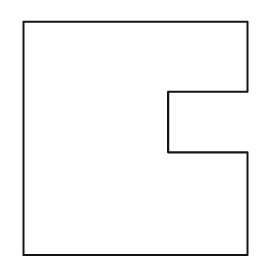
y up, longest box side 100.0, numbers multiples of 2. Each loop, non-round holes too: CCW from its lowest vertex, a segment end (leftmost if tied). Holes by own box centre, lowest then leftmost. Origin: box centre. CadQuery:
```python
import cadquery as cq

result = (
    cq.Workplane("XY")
    .moveTo(-48.0, -50.0)
    .lineTo(48.0, -50.0)
    .lineTo(48.0, -6.0)
    .lineTo(14.0, -6.0)
    .lineTo(14.0, 20.0)
    .lineTo(48.0, 20.0)
    .lineTo(48.0, 50.0)
    .lineTo(-48.0, 50.0)
    .close()
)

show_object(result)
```